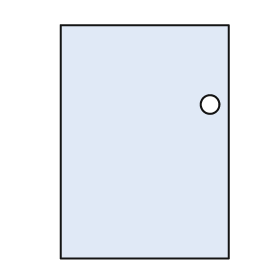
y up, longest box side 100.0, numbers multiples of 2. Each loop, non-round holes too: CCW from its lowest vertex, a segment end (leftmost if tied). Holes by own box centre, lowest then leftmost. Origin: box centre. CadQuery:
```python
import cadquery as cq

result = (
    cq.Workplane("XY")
    .moveTo(-36.0, -50.0)
    .lineTo(36.0, -50.0)
    .lineTo(36.0, 50.0)
    .lineTo(-36.0, 50.0)
    .close()
    .moveTo(28.0, 16.0)
    .circle(4.0)
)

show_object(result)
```